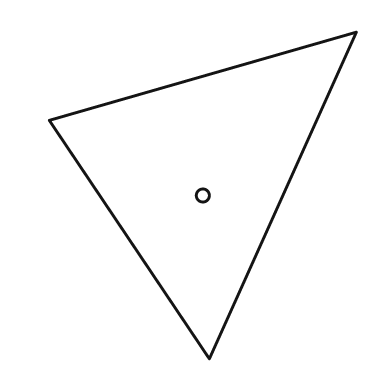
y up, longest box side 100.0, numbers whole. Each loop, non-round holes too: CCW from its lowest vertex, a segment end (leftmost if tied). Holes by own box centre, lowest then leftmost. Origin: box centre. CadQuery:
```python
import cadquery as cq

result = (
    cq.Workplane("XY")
    .moveTo(2.0, -50.0)
    .lineTo(47.0, 50.0)
    .lineTo(-47.0, 23.0)
    .close()
    .moveTo(0.0, 0.0)
    .circle(2.0)
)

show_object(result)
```